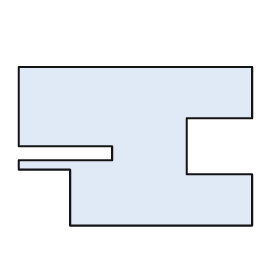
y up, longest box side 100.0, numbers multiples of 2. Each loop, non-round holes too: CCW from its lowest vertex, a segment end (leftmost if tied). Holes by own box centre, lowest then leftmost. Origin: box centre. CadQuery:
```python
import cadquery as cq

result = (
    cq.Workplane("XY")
    .moveTo(-28.0, -34.0)
    .lineTo(50.0, -34.0)
    .lineTo(50.0, -12.0)
    .lineTo(22.0, -12.0)
    .lineTo(22.0, 12.0)
    .lineTo(50.0, 12.0)
    .lineTo(50.0, 34.0)
    .lineTo(-50.0, 34.0)
    .lineTo(-50.0, 0.0)
    .lineTo(-10.0, 0.0)
    .lineTo(-10.0, -6.0)
    .lineTo(-50.0, -6.0)
    .lineTo(-50.0, -10.0)
    .lineTo(-28.0, -10.0)
    .close()
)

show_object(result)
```